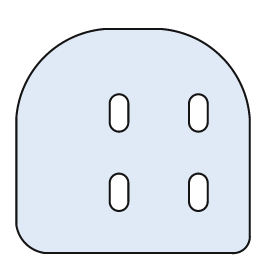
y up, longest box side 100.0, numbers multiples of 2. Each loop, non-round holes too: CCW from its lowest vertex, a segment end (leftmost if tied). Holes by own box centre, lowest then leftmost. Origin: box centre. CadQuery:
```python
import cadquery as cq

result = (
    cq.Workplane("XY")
    .moveTo(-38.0, -48.0)
    .lineTo(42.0, -48.0)
    .threePointArc((48.0, -46.0), (50.0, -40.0))
    .lineTo(50.0, 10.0)
    .threePointArc((38.0, 36.0), (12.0, 48.0))
    .lineTo(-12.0, 48.0)
    .threePointArc((-38.0, 36.0), (-50.0, 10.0))
    .lineTo(-50.0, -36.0)
    .threePointArc((-46.0, -44.0), (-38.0, -48.0))
    .close()
    .moveTo(-10.0, -26.0)
    .threePointArc((-6.0, -30.0), (-2.0, -26.0))
    .lineTo(-2.0, -18.0)
    .threePointArc((-6.0, -14.0), (-10.0, -18.0))
    .close()
    .moveTo(24.0, -26.0)
    .threePointArc((28.0, -30.0), (32.0, -26.0))
    .lineTo(32.0, -18.0)
    .threePointArc((28.0, -14.0), (24.0, -18.0))
    .close()
    .moveTo(-10.0, 8.0)
    .threePointArc((-6.0, 4.0), (-2.0, 8.0))
    .lineTo(-2.0, 16.0)
    .threePointArc((-6.0, 20.0), (-10.0, 16.0))
    .close()
    .moveTo(24.0, 8.0)
    .threePointArc((28.0, 4.0), (32.0, 8.0))
    .lineTo(32.0, 16.0)
    .threePointArc((28.0, 20.0), (24.0, 16.0))
    .close()
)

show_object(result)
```